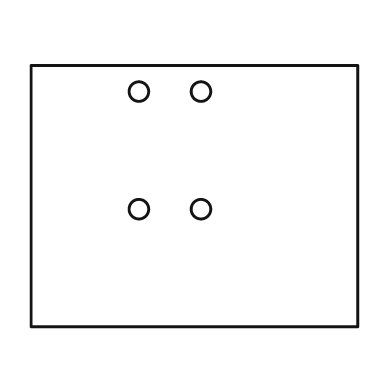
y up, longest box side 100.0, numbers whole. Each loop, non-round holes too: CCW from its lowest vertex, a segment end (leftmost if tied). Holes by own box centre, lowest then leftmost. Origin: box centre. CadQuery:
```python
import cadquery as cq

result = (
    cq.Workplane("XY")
    .moveTo(-50.0, -40.0)
    .lineTo(50.0, -40.0)
    .lineTo(50.0, 40.0)
    .lineTo(-50.0, 40.0)
    .close()
    .moveTo(-17.0, -4.0)
    .circle(3.0)
    .moveTo(2.0, -4.0)
    .circle(3.0)
    .moveTo(-17.0, 32.0)
    .circle(3.0)
    .moveTo(2.0, 32.0)
    .circle(3.0)
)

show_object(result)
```